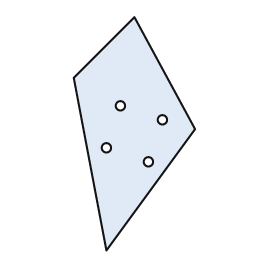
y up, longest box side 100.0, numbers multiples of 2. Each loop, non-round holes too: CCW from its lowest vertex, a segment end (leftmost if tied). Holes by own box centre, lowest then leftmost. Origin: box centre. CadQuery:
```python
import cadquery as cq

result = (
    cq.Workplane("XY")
    .moveTo(-12.0, -50.0)
    .lineTo(26.0, 2.0)
    .lineTo(0.0, 50.0)
    .lineTo(-26.0, 24.0)
    .close()
    .moveTo(6.0, -12.0)
    .circle(2.0)
    .moveTo(-12.0, -6.0)
    .circle(2.0)
    .moveTo(12.0, 6.0)
    .circle(2.0)
    .moveTo(-6.0, 12.0)
    .circle(2.0)
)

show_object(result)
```